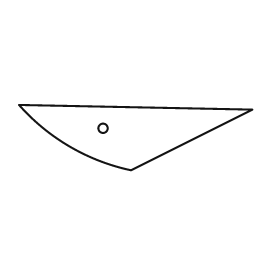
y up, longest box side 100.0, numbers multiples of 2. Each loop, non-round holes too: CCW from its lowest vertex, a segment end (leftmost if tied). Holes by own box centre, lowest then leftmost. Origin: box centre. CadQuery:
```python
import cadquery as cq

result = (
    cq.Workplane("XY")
    .moveTo(-2.0, -14.0)
    .lineTo(50.0, 12.0)
    .lineTo(-50.0, 14.0)
    .threePointArc((-28.0, -4.0), (-2.0, -14.0))
    .close()
    .moveTo(-14.0, 4.0)
    .circle(2.0)
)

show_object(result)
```